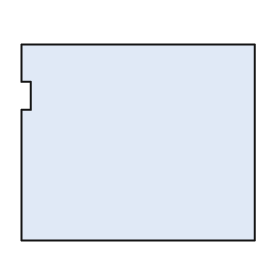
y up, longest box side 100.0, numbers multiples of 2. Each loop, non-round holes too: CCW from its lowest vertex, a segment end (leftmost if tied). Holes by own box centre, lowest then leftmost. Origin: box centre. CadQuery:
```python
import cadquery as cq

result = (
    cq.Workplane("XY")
    .moveTo(-50.0, -42.0)
    .lineTo(50.0, -42.0)
    .lineTo(50.0, 42.0)
    .lineTo(-50.0, 42.0)
    .lineTo(-50.0, 26.0)
    .lineTo(-46.0, 26.0)
    .lineTo(-46.0, 14.0)
    .lineTo(-50.0, 14.0)
    .close()
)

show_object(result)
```